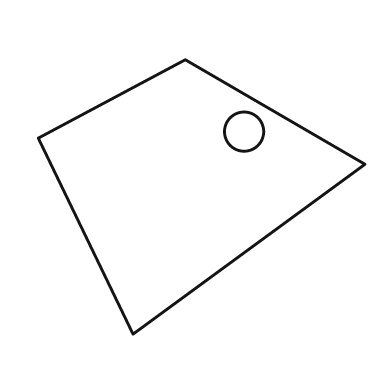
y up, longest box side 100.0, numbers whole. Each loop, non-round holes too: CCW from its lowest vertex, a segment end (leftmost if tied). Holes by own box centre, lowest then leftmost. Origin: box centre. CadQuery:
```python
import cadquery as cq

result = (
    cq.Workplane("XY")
    .moveTo(-21.0, -42.0)
    .lineTo(50.0, 10.0)
    .lineTo(-5.0, 42.0)
    .lineTo(-50.0, 18.0)
    .close()
    .moveTo(13.0, 20.0)
    .circle(6.0)
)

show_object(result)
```